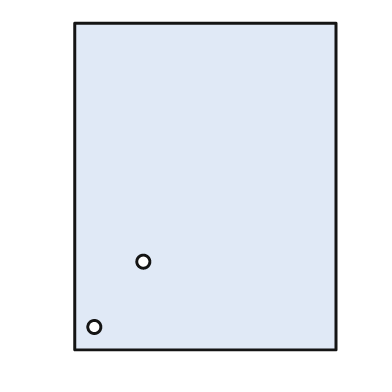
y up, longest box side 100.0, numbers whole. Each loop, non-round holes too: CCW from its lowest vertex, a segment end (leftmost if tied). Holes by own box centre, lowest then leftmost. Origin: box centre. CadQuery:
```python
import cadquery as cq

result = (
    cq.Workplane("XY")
    .moveTo(-40.0, -50.0)
    .lineTo(40.0, -50.0)
    .lineTo(40.0, 50.0)
    .lineTo(-40.0, 50.0)
    .close()
    .moveTo(-34.0, -43.0)
    .circle(2.0)
    .moveTo(-19.0, -23.0)
    .circle(2.0)
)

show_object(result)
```